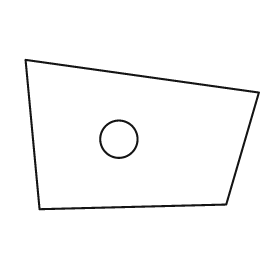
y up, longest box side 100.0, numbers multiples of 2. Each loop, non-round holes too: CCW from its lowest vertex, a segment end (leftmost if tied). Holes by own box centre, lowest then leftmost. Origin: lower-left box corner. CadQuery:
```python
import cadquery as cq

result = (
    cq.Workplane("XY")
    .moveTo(6.0, 0.0)
    .lineTo(86.0, 2.0)
    .lineTo(100.0, 50.0)
    .lineTo(0.0, 64.0)
    .close()
    .moveTo(40.0, 30.0)
    .circle(8.0)
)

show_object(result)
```